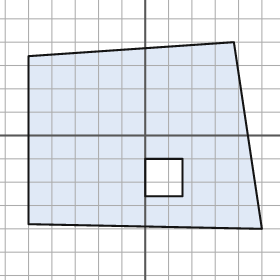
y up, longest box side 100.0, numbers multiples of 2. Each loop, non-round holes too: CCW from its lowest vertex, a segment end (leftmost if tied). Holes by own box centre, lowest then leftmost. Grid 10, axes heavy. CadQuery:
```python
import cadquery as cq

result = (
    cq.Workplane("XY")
    .moveTo(50.0, -40.0)
    .lineTo(38.0, 40.0)
    .lineTo(-50.0, 34.0)
    .lineTo(-50.0, -38.0)
    .close()
    .moveTo(0.0, -26.0)
    .lineTo(16.0, -26.0)
    .lineTo(16.0, -10.0)
    .lineTo(0.0, -10.0)
    .close()
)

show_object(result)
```